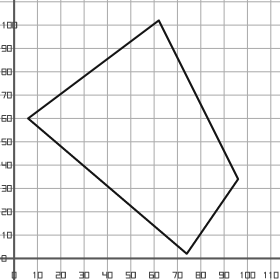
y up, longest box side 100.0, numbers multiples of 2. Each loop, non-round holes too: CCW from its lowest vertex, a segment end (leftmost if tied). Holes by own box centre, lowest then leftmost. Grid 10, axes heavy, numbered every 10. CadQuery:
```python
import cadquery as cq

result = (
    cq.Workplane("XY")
    .moveTo(74.0, 2.0)
    .lineTo(96.0, 34.0)
    .lineTo(62.0, 102.0)
    .lineTo(6.0, 60.0)
    .close()
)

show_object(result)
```